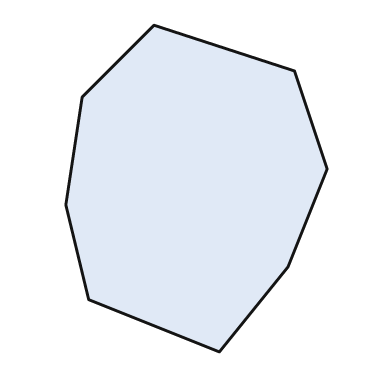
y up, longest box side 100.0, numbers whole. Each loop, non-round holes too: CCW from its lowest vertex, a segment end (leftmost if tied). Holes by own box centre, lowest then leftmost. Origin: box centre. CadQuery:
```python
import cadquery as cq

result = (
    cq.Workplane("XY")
    .moveTo(7.0, -50.0)
    .lineTo(28.0, -24.0)
    .lineTo(40.0, 6.0)
    .lineTo(30.0, 36.0)
    .lineTo(-13.0, 50.0)
    .lineTo(-35.0, 28.0)
    .lineTo(-40.0, -5.0)
    .lineTo(-33.0, -34.0)
    .close()
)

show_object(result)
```